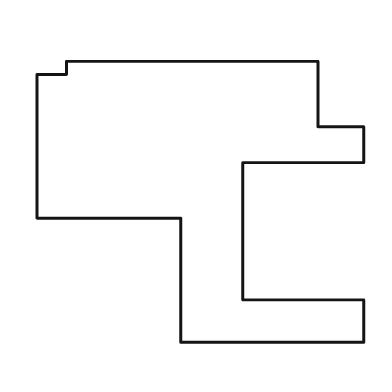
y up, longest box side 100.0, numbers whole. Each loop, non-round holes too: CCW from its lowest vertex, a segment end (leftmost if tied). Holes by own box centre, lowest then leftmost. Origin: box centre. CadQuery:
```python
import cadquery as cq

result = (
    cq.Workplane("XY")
    .moveTo(-6.0, -43.0)
    .lineTo(50.0, -43.0)
    .lineTo(50.0, -30.0)
    .lineTo(13.0, -30.0)
    .lineTo(13.0, 12.0)
    .lineTo(50.0, 12.0)
    .lineTo(50.0, 23.0)
    .lineTo(36.0, 23.0)
    .lineTo(36.0, 43.0)
    .lineTo(-41.0, 43.0)
    .lineTo(-41.0, 39.0)
    .lineTo(-50.0, 39.0)
    .lineTo(-50.0, -5.0)
    .lineTo(-6.0, -5.0)
    .close()
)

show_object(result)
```